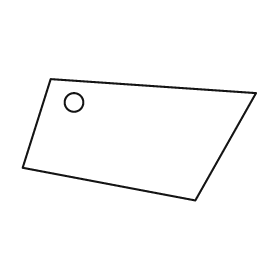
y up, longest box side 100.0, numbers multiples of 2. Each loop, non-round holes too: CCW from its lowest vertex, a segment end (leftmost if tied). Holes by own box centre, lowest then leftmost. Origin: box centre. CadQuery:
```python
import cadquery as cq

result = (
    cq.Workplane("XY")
    .moveTo(24.0, -26.0)
    .lineTo(50.0, 20.0)
    .lineTo(-38.0, 26.0)
    .lineTo(-50.0, -12.0)
    .close()
    .moveTo(-28.0, 16.0)
    .circle(4.0)
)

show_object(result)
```